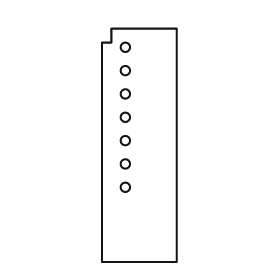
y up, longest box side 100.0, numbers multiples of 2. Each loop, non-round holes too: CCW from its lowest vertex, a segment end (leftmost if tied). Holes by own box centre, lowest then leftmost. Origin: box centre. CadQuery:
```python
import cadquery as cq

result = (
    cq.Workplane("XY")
    .moveTo(-16.0, -50.0)
    .lineTo(16.0, -50.0)
    .lineTo(16.0, 50.0)
    .lineTo(-12.0, 50.0)
    .lineTo(-12.0, 44.0)
    .lineTo(-16.0, 44.0)
    .close()
    .moveTo(-6.0, -18.0)
    .circle(2.0)
    .moveTo(-6.0, -8.0)
    .circle(2.0)
    .moveTo(-6.0, 2.0)
    .circle(2.0)
    .moveTo(-6.0, 12.0)
    .circle(2.0)
    .moveTo(-6.0, 22.0)
    .circle(2.0)
    .moveTo(-6.0, 32.0)
    .circle(2.0)
    .moveTo(-6.0, 42.0)
    .circle(2.0)
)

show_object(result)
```